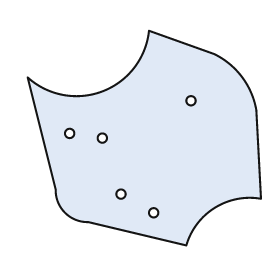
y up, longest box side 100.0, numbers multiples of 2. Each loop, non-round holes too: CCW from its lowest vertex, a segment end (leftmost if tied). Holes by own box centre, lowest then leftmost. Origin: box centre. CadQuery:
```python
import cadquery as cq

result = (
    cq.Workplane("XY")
    .moveTo(18.0, -46.0)
    .threePointArc((30.0, -30.0), (50.0, -26.0))
    .lineTo(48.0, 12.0)
    .threePointArc((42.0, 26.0), (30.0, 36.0))
    .lineTo(2.0, 46.0)
    .threePointArc((-18.0, 20.0), (-50.0, 26.0))
    .lineTo(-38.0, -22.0)
    .threePointArc((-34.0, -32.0), (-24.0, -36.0))
    .close()
    .moveTo(4.0, -32.0)
    .circle(2.0)
    .moveTo(-10.0, -24.0)
    .circle(2.0)
    .moveTo(-18.0, 0.0)
    .circle(2.0)
    .moveTo(-32.0, 2.0)
    .circle(2.0)
    .moveTo(20.0, 16.0)
    .circle(2.0)
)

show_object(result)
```